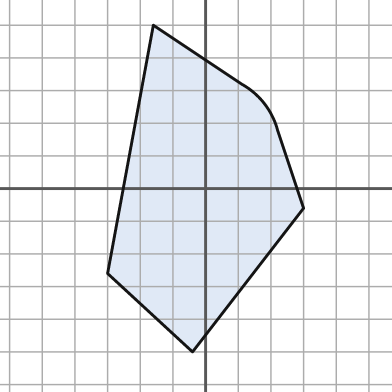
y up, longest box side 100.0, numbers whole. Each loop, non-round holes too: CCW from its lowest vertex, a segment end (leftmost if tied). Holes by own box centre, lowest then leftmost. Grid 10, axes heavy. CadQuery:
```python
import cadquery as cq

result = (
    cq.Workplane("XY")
    .moveTo(-4.0, -50.0)
    .lineTo(30.0, -6.0)
    .lineTo(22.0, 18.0)
    .threePointArc((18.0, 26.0), (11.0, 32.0))
    .lineTo(-16.0, 50.0)
    .lineTo(-30.0, -26.0)
    .close()
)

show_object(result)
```